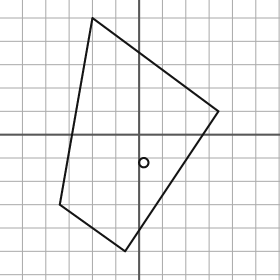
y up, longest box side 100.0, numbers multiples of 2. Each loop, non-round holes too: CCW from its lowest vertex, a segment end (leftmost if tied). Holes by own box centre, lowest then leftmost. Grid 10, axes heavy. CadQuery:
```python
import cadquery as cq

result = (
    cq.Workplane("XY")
    .moveTo(-6.0, -50.0)
    .lineTo(34.0, 10.0)
    .lineTo(-20.0, 50.0)
    .lineTo(-34.0, -30.0)
    .close()
    .moveTo(2.0, -12.0)
    .circle(2.0)
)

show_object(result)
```